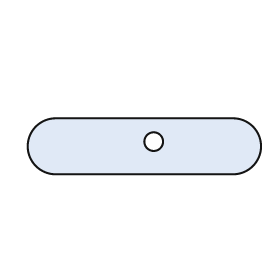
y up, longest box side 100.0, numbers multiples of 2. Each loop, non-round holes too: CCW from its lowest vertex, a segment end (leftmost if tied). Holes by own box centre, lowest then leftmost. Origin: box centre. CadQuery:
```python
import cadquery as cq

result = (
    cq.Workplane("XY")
    .moveTo(-38.0, -12.0)
    .lineTo(38.0, -12.0)
    .threePointArc((50.0, 0.0), (38.0, 12.0))
    .lineTo(-38.0, 12.0)
    .threePointArc((-50.0, 0.0), (-38.0, -12.0))
    .close()
    .moveTo(4.0, 2.0)
    .circle(4.0)
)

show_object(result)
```